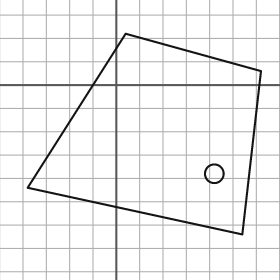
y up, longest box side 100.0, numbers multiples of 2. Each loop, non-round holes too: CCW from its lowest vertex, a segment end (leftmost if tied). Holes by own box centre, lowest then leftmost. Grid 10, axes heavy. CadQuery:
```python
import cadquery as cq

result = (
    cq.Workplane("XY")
    .moveTo(54.0, -64.0)
    .lineTo(62.0, 6.0)
    .lineTo(4.0, 22.0)
    .lineTo(-38.0, -44.0)
    .close()
    .moveTo(42.0, -38.0)
    .circle(4.0)
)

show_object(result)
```